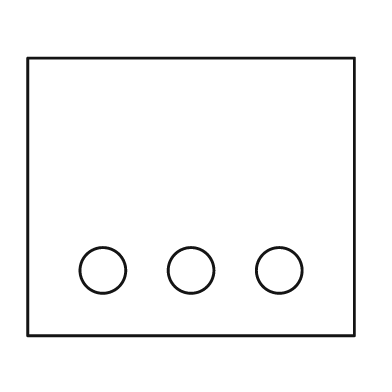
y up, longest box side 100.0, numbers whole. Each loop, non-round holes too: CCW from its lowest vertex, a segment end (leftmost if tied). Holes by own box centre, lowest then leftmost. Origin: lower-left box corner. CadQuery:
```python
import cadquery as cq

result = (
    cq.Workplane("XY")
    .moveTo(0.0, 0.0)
    .lineTo(100.0, 0.0)
    .lineTo(100.0, 85.0)
    .lineTo(0.0, 85.0)
    .close()
    .moveTo(23.0, 20.0)
    .circle(7.0)
    .moveTo(50.0, 20.0)
    .circle(7.0)
    .moveTo(77.0, 20.0)
    .circle(7.0)
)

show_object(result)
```